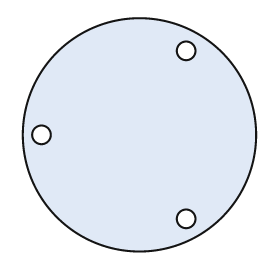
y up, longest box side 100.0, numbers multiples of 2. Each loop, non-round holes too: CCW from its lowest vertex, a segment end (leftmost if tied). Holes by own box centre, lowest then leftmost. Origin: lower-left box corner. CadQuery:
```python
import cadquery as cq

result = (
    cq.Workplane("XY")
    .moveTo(50.0, 50.0)
    .circle(50.0)
    .moveTo(70.0, 14.0)
    .circle(4.0)
    .moveTo(8.0, 50.0)
    .circle(4.0)
    .moveTo(70.0, 86.0)
    .circle(4.0)
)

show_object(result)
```